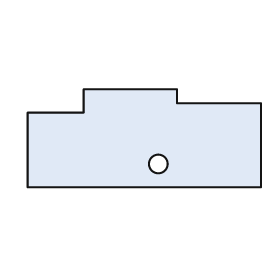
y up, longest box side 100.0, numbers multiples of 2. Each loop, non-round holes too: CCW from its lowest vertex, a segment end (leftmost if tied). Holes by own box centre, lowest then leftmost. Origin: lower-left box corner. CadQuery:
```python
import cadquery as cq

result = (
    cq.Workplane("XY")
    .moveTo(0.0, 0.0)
    .lineTo(100.0, 0.0)
    .lineTo(100.0, 36.0)
    .lineTo(64.0, 36.0)
    .lineTo(64.0, 42.0)
    .lineTo(24.0, 42.0)
    .lineTo(24.0, 32.0)
    .lineTo(0.0, 32.0)
    .close()
    .moveTo(56.0, 10.0)
    .circle(4.0)
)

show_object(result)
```